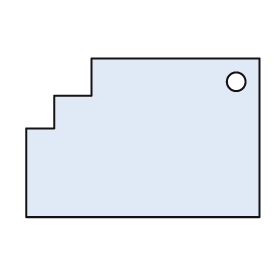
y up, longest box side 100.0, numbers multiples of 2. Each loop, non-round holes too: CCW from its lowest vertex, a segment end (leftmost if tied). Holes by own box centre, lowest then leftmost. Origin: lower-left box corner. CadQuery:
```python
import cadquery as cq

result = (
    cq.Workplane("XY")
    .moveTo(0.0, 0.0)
    .lineTo(100.0, 0.0)
    .lineTo(100.0, 68.0)
    .lineTo(28.0, 68.0)
    .lineTo(28.0, 52.0)
    .lineTo(12.0, 52.0)
    .lineTo(12.0, 38.0)
    .lineTo(0.0, 38.0)
    .close()
    .moveTo(90.0, 58.0)
    .circle(4.0)
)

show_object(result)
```